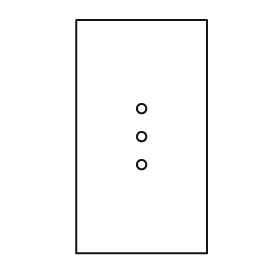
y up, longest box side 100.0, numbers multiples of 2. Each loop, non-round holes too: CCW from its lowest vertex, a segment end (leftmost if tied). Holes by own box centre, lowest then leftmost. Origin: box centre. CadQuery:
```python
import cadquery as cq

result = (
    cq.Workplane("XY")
    .moveTo(-28.0, -50.0)
    .lineTo(28.0, -50.0)
    .lineTo(28.0, 50.0)
    .lineTo(-28.0, 50.0)
    .close()
    .moveTo(0.0, -12.0)
    .circle(2.0)
    .moveTo(0.0, 0.0)
    .circle(2.0)
    .moveTo(0.0, 12.0)
    .circle(2.0)
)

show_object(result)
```